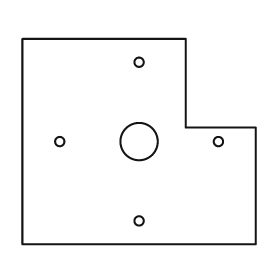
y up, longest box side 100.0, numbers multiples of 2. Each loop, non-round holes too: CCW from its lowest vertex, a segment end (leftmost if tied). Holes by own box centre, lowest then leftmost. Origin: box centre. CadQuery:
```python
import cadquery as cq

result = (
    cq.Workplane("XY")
    .moveTo(-50.0, -44.0)
    .lineTo(50.0, -44.0)
    .lineTo(50.0, 6.0)
    .lineTo(20.0, 6.0)
    .lineTo(20.0, 44.0)
    .lineTo(-50.0, 44.0)
    .close()
    .moveTo(0.0, -34.0)
    .circle(2.0)
    .moveTo(-34.0, 0.0)
    .circle(2.0)
    .moveTo(0.0, 0.0)
    .circle(8.0)
    .moveTo(34.0, 0.0)
    .circle(2.0)
    .moveTo(0.0, 34.0)
    .circle(2.0)
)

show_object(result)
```